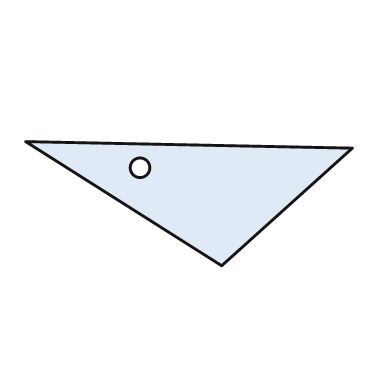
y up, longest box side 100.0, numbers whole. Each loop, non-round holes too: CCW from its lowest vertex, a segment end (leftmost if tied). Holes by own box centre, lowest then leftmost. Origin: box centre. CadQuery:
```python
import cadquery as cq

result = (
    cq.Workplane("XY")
    .moveTo(10.0, -19.0)
    .lineTo(50.0, 17.0)
    .lineTo(-50.0, 19.0)
    .close()
    .moveTo(-15.0, 11.0)
    .circle(3.0)
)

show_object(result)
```